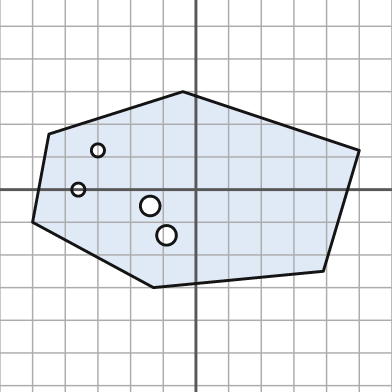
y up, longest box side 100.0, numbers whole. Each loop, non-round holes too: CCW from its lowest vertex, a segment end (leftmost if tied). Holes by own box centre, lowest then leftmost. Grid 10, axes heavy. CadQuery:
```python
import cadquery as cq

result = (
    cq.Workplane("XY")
    .moveTo(-13.0, -30.0)
    .lineTo(39.0, -25.0)
    .lineTo(50.0, 12.0)
    .lineTo(-4.0, 30.0)
    .lineTo(-45.0, 17.0)
    .lineTo(-50.0, -10.0)
    .close()
    .moveTo(-9.0, -14.0)
    .circle(3.0)
    .moveTo(-14.0, -5.0)
    .circle(3.0)
    .moveTo(-36.0, 0.0)
    .circle(2.0)
    .moveTo(-30.0, 12.0)
    .circle(2.0)
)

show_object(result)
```